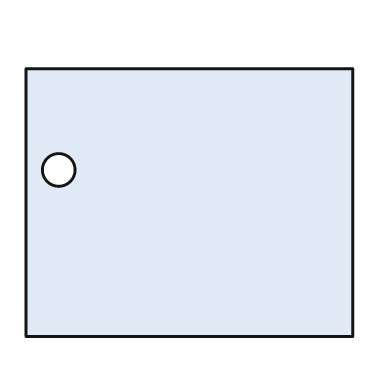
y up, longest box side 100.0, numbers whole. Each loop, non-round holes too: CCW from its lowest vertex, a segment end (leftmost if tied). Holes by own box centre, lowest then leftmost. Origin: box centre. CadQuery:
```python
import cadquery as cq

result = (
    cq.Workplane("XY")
    .moveTo(-50.0, -41.0)
    .lineTo(50.0, -41.0)
    .lineTo(50.0, 41.0)
    .lineTo(-50.0, 41.0)
    .close()
    .moveTo(-40.0, 10.0)
    .circle(5.0)
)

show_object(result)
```